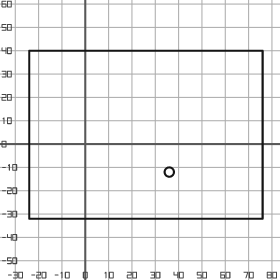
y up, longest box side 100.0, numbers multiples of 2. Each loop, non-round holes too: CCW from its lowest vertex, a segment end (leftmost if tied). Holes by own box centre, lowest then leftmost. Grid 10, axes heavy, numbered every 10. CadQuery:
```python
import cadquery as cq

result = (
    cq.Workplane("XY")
    .moveTo(-24.0, -32.0)
    .lineTo(76.0, -32.0)
    .lineTo(76.0, 40.0)
    .lineTo(-24.0, 40.0)
    .close()
    .moveTo(36.0, -12.0)
    .circle(2.0)
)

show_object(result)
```